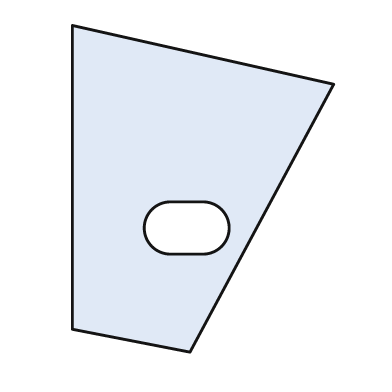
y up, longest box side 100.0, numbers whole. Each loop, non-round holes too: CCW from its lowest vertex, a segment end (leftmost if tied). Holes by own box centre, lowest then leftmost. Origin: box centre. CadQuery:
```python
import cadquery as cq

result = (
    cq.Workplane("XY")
    .moveTo(-4.0, -50.0)
    .lineTo(40.0, 32.0)
    .lineTo(-40.0, 50.0)
    .lineTo(-40.0, -43.0)
    .close()
    .moveTo(-10.0, -20.0)
    .lineTo(0.0, -20.0)
    .threePointArc((8.0, -12.0), (0.0, -4.0))
    .lineTo(-10.0, -4.0)
    .threePointArc((-18.0, -12.0), (-10.0, -20.0))
    .close()
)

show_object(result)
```